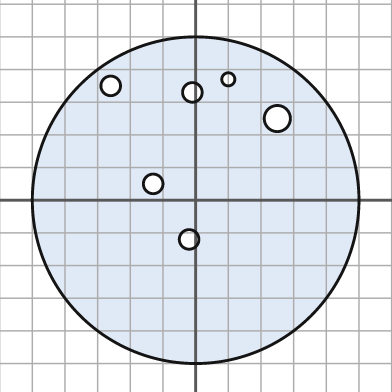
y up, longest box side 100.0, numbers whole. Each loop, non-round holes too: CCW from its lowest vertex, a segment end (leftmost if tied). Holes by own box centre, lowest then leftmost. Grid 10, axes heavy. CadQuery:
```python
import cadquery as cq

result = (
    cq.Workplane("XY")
    .moveTo(0.0, 0.0)
    .circle(50.0)
    .moveTo(-2.0, -12.0)
    .circle(3.0)
    .moveTo(-13.0, 5.0)
    .circle(3.0)
    .moveTo(25.0, 25.0)
    .circle(4.0)
    .moveTo(-1.0, 33.0)
    .circle(3.0)
    .moveTo(-26.0, 35.0)
    .circle(3.0)
    .moveTo(10.0, 37.0)
    .circle(2.0)
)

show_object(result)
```